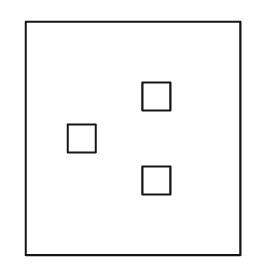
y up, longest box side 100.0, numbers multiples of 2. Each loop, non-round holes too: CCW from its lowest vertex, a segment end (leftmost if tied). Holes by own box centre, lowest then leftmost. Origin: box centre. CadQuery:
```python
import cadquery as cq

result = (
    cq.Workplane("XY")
    .moveTo(-46.0, -50.0)
    .lineTo(46.0, -50.0)
    .lineTo(46.0, 50.0)
    .lineTo(-46.0, 50.0)
    .close()
    .moveTo(4.0, -24.0)
    .lineTo(16.0, -24.0)
    .lineTo(16.0, -12.0)
    .lineTo(4.0, -12.0)
    .close()
    .moveTo(-28.0, -6.0)
    .lineTo(-16.0, -6.0)
    .lineTo(-16.0, 6.0)
    .lineTo(-28.0, 6.0)
    .close()
    .moveTo(4.0, 12.0)
    .lineTo(16.0, 12.0)
    .lineTo(16.0, 24.0)
    .lineTo(4.0, 24.0)
    .close()
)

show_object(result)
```